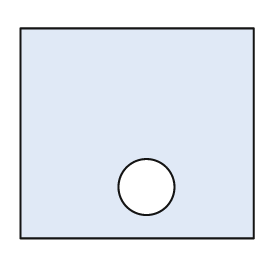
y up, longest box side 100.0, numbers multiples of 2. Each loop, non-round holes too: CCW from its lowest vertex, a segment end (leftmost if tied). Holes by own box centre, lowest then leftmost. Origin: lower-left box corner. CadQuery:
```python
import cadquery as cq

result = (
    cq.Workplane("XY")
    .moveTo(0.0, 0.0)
    .lineTo(100.0, 0.0)
    .lineTo(100.0, 90.0)
    .lineTo(0.0, 90.0)
    .close()
    .moveTo(54.0, 22.0)
    .circle(12.0)
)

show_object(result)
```